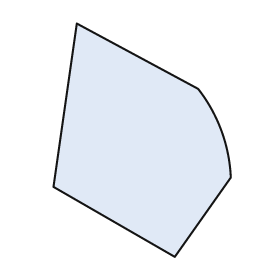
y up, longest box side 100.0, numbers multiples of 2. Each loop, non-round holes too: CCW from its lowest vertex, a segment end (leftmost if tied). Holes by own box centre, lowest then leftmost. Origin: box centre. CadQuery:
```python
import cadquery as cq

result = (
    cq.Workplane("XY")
    .moveTo(14.0, -50.0)
    .lineTo(38.0, -16.0)
    .threePointArc((34.0, 4.0), (24.0, 22.0))
    .lineTo(-28.0, 50.0)
    .lineTo(-38.0, -20.0)
    .close()
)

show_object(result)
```